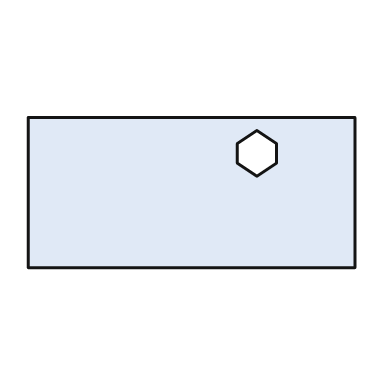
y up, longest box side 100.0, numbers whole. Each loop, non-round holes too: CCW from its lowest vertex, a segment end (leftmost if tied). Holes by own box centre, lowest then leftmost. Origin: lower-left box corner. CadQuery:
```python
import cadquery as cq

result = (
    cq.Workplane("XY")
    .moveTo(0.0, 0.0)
    .lineTo(100.0, 0.0)
    .lineTo(100.0, 46.0)
    .lineTo(0.0, 46.0)
    .close()
    .moveTo(70.0, 28.0)
    .lineTo(76.0, 32.0)
    .lineTo(76.0, 38.0)
    .lineTo(70.0, 42.0)
    .lineTo(64.0, 38.0)
    .lineTo(64.0, 32.0)
    .close()
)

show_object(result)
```